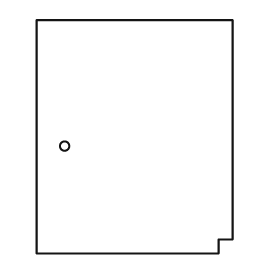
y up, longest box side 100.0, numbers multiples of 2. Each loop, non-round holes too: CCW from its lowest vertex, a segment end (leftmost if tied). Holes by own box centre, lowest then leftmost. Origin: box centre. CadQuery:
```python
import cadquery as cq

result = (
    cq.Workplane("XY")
    .moveTo(-42.0, -50.0)
    .lineTo(36.0, -50.0)
    .lineTo(36.0, -44.0)
    .lineTo(42.0, -44.0)
    .lineTo(42.0, 50.0)
    .lineTo(-42.0, 50.0)
    .close()
    .moveTo(-30.0, -4.0)
    .circle(2.0)
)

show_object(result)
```